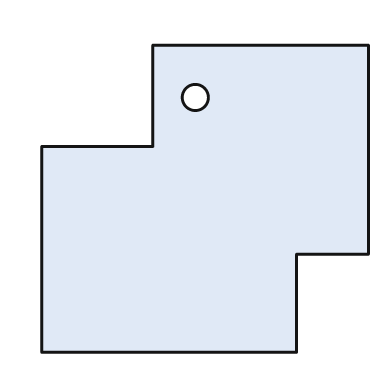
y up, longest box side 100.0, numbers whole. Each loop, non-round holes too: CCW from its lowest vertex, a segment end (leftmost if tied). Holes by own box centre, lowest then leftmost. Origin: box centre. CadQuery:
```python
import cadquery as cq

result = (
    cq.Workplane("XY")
    .moveTo(-50.0, -47.0)
    .lineTo(28.0, -47.0)
    .lineTo(28.0, -17.0)
    .lineTo(50.0, -17.0)
    .lineTo(50.0, 47.0)
    .lineTo(-16.0, 47.0)
    .lineTo(-16.0, 16.0)
    .lineTo(-50.0, 16.0)
    .close()
    .moveTo(-3.0, 31.0)
    .circle(4.0)
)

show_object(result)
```